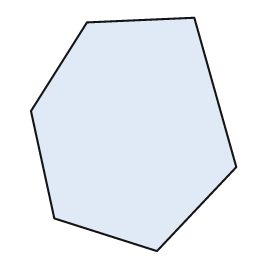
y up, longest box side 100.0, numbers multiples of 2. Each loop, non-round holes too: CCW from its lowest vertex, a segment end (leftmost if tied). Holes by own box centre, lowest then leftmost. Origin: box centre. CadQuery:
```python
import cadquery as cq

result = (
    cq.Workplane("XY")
    .moveTo(10.0, -50.0)
    .lineTo(44.0, -14.0)
    .lineTo(26.0, 50.0)
    .lineTo(-20.0, 48.0)
    .lineTo(-44.0, 10.0)
    .lineTo(-34.0, -36.0)
    .close()
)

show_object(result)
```